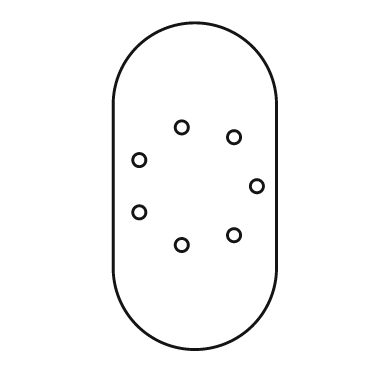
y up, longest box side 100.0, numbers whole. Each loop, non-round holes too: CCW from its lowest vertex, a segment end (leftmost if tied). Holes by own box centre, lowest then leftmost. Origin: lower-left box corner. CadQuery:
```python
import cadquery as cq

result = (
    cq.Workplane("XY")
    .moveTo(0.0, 25.0)
    .threePointArc((25.0, 0.0), (50.0, 25.0))
    .lineTo(50.0, 75.0)
    .threePointArc((25.0, 100.0), (0.0, 75.0))
    .close()
    .moveTo(21.0, 32.0)
    .circle(2.0)
    .moveTo(37.0, 35.0)
    .circle(2.0)
    .moveTo(8.0, 42.0)
    .circle(2.0)
    .moveTo(44.0, 50.0)
    .circle(2.0)
    .moveTo(8.0, 58.0)
    .circle(2.0)
    .moveTo(37.0, 65.0)
    .circle(2.0)
    .moveTo(21.0, 68.0)
    .circle(2.0)
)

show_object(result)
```